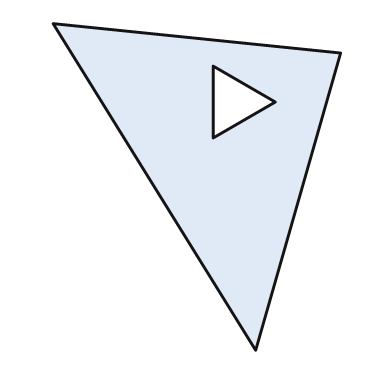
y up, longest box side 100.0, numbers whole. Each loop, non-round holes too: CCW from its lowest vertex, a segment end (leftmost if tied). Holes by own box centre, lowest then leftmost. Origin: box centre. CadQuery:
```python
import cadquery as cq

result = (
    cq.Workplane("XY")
    .moveTo(18.0, -50.0)
    .lineTo(44.0, 41.0)
    .lineTo(-44.0, 50.0)
    .close()
    .moveTo(5.0, 15.0)
    .lineTo(24.0, 26.0)
    .lineTo(5.0, 37.0)
    .close()
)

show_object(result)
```